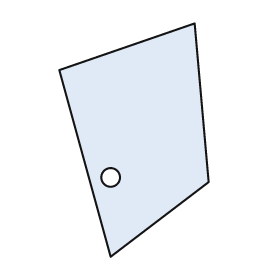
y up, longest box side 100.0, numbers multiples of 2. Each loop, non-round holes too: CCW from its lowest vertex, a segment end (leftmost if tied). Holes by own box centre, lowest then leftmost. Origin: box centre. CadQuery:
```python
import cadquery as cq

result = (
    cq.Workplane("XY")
    .moveTo(-10.0, -50.0)
    .lineTo(32.0, -18.0)
    .lineTo(26.0, 50.0)
    .lineTo(-32.0, 30.0)
    .close()
    .moveTo(-10.0, -16.0)
    .circle(4.0)
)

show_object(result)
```